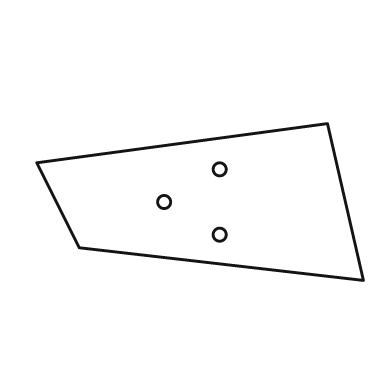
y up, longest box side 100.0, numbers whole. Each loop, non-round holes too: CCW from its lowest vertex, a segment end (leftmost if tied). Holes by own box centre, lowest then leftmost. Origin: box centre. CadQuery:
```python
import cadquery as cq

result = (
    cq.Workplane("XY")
    .moveTo(50.0, -24.0)
    .lineTo(39.0, 24.0)
    .lineTo(-50.0, 12.0)
    .lineTo(-37.0, -14.0)
    .close()
    .moveTo(6.0, -10.0)
    .circle(2.0)
    .moveTo(-11.0, 0.0)
    .circle(2.0)
    .moveTo(6.0, 10.0)
    .circle(2.0)
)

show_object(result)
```